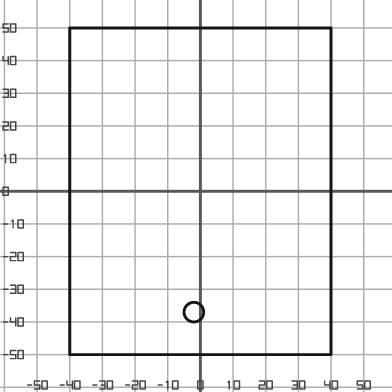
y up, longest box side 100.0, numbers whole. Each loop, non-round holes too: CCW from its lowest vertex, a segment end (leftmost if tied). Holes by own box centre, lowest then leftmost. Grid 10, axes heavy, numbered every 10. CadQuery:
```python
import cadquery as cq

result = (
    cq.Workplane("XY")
    .moveTo(-40.0, -50.0)
    .lineTo(40.0, -50.0)
    .lineTo(40.0, 50.0)
    .lineTo(-40.0, 50.0)
    .close()
    .moveTo(-2.0, -37.0)
    .circle(3.0)
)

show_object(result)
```